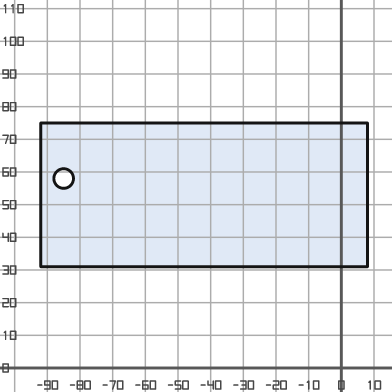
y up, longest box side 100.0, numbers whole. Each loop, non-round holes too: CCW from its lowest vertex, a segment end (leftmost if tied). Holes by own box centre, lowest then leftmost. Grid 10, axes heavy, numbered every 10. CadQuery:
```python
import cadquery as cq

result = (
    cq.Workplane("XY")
    .moveTo(-92.0, 31.0)
    .lineTo(8.0, 31.0)
    .lineTo(8.0, 75.0)
    .lineTo(-92.0, 75.0)
    .close()
    .moveTo(-85.0, 58.0)
    .circle(3.0)
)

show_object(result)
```